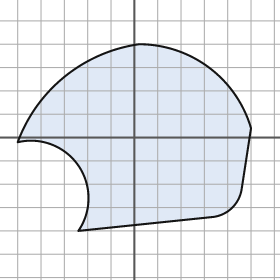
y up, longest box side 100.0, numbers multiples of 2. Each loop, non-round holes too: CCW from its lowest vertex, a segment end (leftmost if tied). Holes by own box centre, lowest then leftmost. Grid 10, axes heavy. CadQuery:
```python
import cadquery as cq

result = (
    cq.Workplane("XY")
    .moveTo(-24.0, -40.0)
    .lineTo(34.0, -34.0)
    .threePointArc((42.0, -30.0), (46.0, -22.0))
    .lineTo(50.0, 4.0)
    .threePointArc((32.0, 30.0), (2.0, 40.0))
    .threePointArc((-30.0, 26.0), (-50.0, -2.0))
    .threePointArc((-24.0, -12.0), (-24.0, -40.0))
    .close()
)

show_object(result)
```